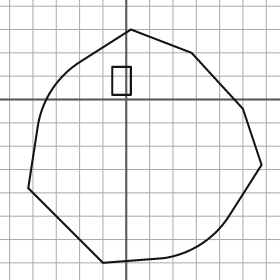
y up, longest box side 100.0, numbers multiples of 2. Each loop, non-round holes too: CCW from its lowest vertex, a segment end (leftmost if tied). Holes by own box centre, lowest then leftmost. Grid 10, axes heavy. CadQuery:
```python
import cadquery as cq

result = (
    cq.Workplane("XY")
    .moveTo(-10.0, -70.0)
    .lineTo(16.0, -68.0)
    .threePointArc((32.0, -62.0), (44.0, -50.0))
    .lineTo(58.0, -28.0)
    .lineTo(50.0, -4.0)
    .lineTo(28.0, 20.0)
    .lineTo(2.0, 30.0)
    .lineTo(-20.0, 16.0)
    .threePointArc((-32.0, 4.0), (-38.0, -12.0))
    .lineTo(-42.0, -38.0)
    .close()
    .moveTo(-6.0, 2.0)
    .lineTo(2.0, 2.0)
    .lineTo(2.0, 14.0)
    .lineTo(-6.0, 14.0)
    .close()
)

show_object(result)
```